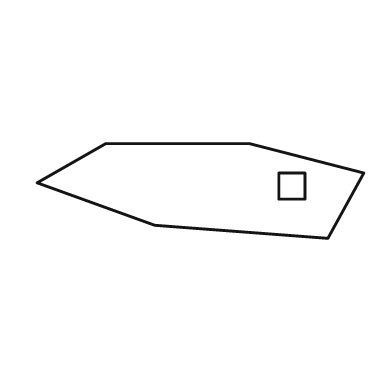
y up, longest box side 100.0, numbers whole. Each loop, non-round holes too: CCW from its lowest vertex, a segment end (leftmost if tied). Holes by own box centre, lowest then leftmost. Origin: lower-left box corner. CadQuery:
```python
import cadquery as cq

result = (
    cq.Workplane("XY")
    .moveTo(89.0, 0.0)
    .lineTo(100.0, 20.0)
    .lineTo(65.0, 29.0)
    .lineTo(21.0, 29.0)
    .lineTo(0.0, 17.0)
    .lineTo(36.0, 4.0)
    .close()
    .moveTo(74.0, 12.0)
    .lineTo(82.0, 12.0)
    .lineTo(82.0, 20.0)
    .lineTo(74.0, 20.0)
    .close()
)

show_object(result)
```